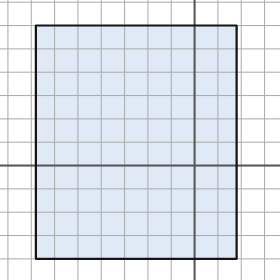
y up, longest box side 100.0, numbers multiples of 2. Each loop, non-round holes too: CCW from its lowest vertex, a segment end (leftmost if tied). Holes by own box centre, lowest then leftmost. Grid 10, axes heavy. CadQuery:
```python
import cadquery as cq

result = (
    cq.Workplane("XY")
    .moveTo(-68.0, -40.0)
    .lineTo(18.0, -40.0)
    .lineTo(18.0, 60.0)
    .lineTo(-68.0, 60.0)
    .close()
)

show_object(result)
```